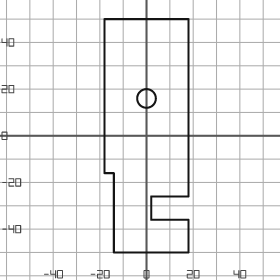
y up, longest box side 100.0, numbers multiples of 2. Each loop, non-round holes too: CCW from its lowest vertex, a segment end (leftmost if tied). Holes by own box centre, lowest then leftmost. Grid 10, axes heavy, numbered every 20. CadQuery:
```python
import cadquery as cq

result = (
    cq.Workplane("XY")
    .moveTo(-14.0, -50.0)
    .lineTo(18.0, -50.0)
    .lineTo(18.0, -36.0)
    .lineTo(2.0, -36.0)
    .lineTo(2.0, -26.0)
    .lineTo(18.0, -26.0)
    .lineTo(18.0, 50.0)
    .lineTo(-18.0, 50.0)
    .lineTo(-18.0, -16.0)
    .lineTo(-14.0, -16.0)
    .close()
    .moveTo(0.0, 16.0)
    .circle(4.0)
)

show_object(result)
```